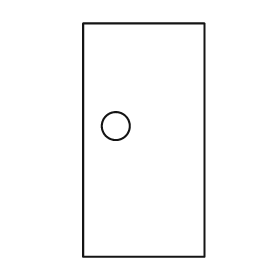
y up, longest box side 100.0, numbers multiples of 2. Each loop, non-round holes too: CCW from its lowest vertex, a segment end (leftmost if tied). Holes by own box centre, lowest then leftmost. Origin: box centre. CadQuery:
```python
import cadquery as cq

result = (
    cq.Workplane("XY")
    .moveTo(-26.0, -50.0)
    .lineTo(26.0, -50.0)
    .lineTo(26.0, 50.0)
    .lineTo(-26.0, 50.0)
    .close()
    .moveTo(-12.0, 6.0)
    .circle(6.0)
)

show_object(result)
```